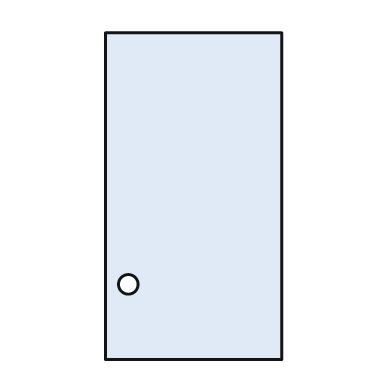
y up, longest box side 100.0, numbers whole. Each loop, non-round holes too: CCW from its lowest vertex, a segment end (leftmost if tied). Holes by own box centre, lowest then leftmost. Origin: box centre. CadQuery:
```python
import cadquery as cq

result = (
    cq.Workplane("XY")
    .moveTo(-27.0, -50.0)
    .lineTo(27.0, -50.0)
    .lineTo(27.0, 50.0)
    .lineTo(-27.0, 50.0)
    .close()
    .moveTo(-20.0, -27.0)
    .circle(3.0)
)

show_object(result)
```